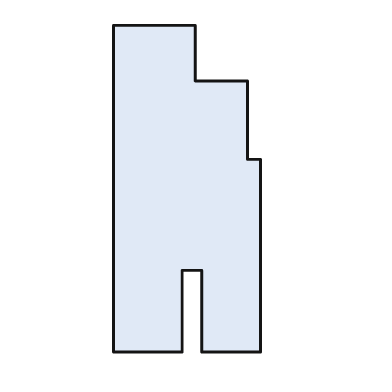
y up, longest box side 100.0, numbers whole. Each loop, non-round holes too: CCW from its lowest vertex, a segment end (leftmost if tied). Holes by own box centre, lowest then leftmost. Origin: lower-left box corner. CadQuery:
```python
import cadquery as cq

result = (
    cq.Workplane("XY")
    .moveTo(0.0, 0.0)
    .lineTo(21.0, 0.0)
    .lineTo(21.0, 25.0)
    .lineTo(27.0, 25.0)
    .lineTo(27.0, 0.0)
    .lineTo(45.0, 0.0)
    .lineTo(45.0, 59.0)
    .lineTo(41.0, 59.0)
    .lineTo(41.0, 83.0)
    .lineTo(25.0, 83.0)
    .lineTo(25.0, 100.0)
    .lineTo(0.0, 100.0)
    .close()
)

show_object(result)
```